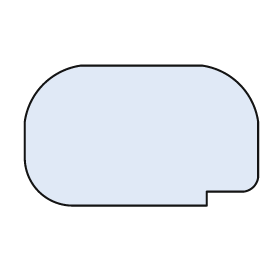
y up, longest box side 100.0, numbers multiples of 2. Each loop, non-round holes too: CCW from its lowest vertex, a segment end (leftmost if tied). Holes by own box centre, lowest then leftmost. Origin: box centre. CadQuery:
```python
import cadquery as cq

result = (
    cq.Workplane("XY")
    .moveTo(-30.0, -30.0)
    .lineTo(28.0, -30.0)
    .lineTo(28.0, -24.0)
    .lineTo(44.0, -24.0)
    .threePointArc((48.0, -22.0), (50.0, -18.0))
    .lineTo(50.0, 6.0)
    .threePointArc((42.0, 22.0), (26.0, 30.0))
    .lineTo(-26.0, 30.0)
    .threePointArc((-42.0, 22.0), (-50.0, 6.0))
    .lineTo(-50.0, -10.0)
    .threePointArc((-44.0, -24.0), (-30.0, -30.0))
    .close()
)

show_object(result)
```